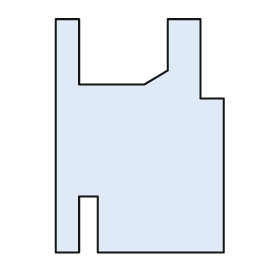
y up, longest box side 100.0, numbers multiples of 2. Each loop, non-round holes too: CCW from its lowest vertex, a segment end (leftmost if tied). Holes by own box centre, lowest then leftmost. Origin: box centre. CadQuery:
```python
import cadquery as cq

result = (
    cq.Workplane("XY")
    .moveTo(-36.0, -50.0)
    .lineTo(-26.0, -50.0)
    .lineTo(-26.0, -26.0)
    .lineTo(-18.0, -26.0)
    .lineTo(-18.0, -50.0)
    .lineTo(36.0, -50.0)
    .lineTo(36.0, 16.0)
    .lineTo(26.0, 16.0)
    .lineTo(26.0, 50.0)
    .lineTo(12.0, 50.0)
    .lineTo(12.0, 28.0)
    .lineTo(2.0, 22.0)
    .lineTo(-26.0, 22.0)
    .lineTo(-26.0, 50.0)
    .lineTo(-36.0, 50.0)
    .close()
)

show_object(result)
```